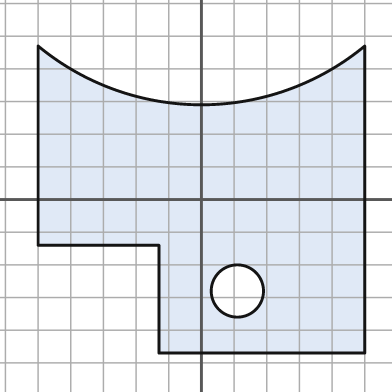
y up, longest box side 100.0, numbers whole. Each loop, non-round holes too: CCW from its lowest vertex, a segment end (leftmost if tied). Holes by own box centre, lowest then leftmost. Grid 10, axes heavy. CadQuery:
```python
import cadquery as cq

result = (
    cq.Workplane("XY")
    .moveTo(-13.0, -47.0)
    .lineTo(50.0, -47.0)
    .lineTo(50.0, 47.0)
    .threePointArc((0.0, 29.0), (-50.0, 47.0))
    .lineTo(-50.0, -14.0)
    .lineTo(-13.0, -14.0)
    .close()
    .moveTo(11.0, -28.0)
    .circle(8.0)
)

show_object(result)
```